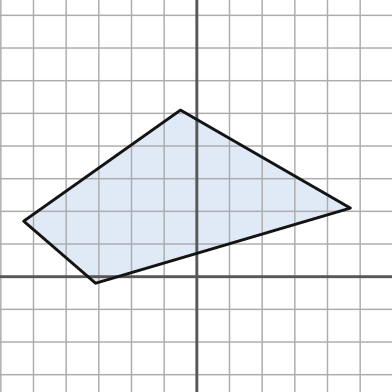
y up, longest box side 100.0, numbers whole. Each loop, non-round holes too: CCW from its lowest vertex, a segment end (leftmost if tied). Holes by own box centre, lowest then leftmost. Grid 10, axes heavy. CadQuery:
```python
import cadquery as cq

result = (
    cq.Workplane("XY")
    .moveTo(-31.0, -2.0)
    .lineTo(47.0, 21.0)
    .lineTo(-5.0, 51.0)
    .lineTo(-53.0, 17.0)
    .close()
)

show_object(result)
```